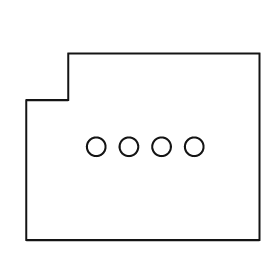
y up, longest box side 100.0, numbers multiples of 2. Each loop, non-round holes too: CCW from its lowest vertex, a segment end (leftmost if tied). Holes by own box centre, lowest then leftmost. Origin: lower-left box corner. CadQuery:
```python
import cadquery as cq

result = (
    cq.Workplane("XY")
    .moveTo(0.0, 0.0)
    .lineTo(100.0, 0.0)
    .lineTo(100.0, 80.0)
    .lineTo(18.0, 80.0)
    .lineTo(18.0, 60.0)
    .lineTo(0.0, 60.0)
    .close()
    .moveTo(30.0, 40.0)
    .circle(4.0)
    .moveTo(44.0, 40.0)
    .circle(4.0)
    .moveTo(58.0, 40.0)
    .circle(4.0)
    .moveTo(72.0, 40.0)
    .circle(4.0)
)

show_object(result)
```